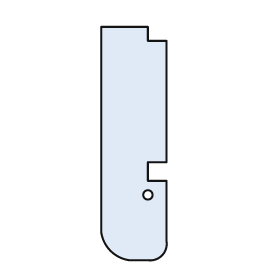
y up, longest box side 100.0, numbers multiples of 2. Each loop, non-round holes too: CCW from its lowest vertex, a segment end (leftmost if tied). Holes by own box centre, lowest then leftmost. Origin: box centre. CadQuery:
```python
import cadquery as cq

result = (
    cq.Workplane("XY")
    .moveTo(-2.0, -50.0)
    .lineTo(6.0, -50.0)
    .threePointArc((12.0, -48.0), (14.0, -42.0))
    .lineTo(14.0, -16.0)
    .lineTo(6.0, -16.0)
    .lineTo(6.0, -8.0)
    .lineTo(14.0, -8.0)
    .lineTo(14.0, 44.0)
    .lineTo(6.0, 44.0)
    .lineTo(6.0, 50.0)
    .lineTo(-14.0, 50.0)
    .lineTo(-14.0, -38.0)
    .threePointArc((-10.0, -46.0), (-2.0, -50.0))
    .close()
    .moveTo(6.0, -22.0)
    .circle(2.0)
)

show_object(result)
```